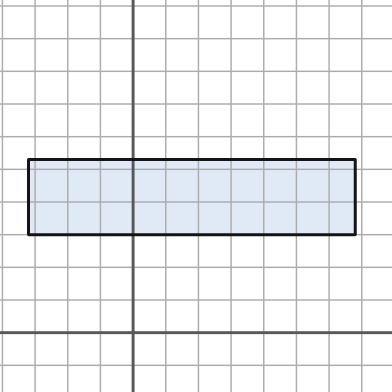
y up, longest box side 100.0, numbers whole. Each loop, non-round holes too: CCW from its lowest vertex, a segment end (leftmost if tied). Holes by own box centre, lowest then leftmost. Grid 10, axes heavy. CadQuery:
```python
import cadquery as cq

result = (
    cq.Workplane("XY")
    .moveTo(-32.0, 30.0)
    .lineTo(68.0, 30.0)
    .lineTo(68.0, 53.0)
    .lineTo(-32.0, 53.0)
    .close()
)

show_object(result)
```